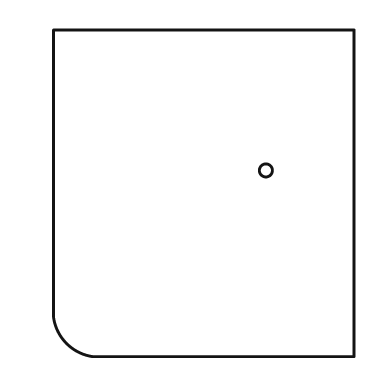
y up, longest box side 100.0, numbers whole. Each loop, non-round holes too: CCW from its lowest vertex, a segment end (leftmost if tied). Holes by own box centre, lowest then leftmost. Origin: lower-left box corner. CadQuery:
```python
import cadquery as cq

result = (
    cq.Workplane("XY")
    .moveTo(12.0, 0.0)
    .lineTo(92.0, 0.0)
    .lineTo(92.0, 100.0)
    .lineTo(0.0, 100.0)
    .lineTo(0.0, 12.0)
    .threePointArc((4.0, 4.0), (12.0, 0.0))
    .close()
    .moveTo(65.0, 57.0)
    .circle(2.0)
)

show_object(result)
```